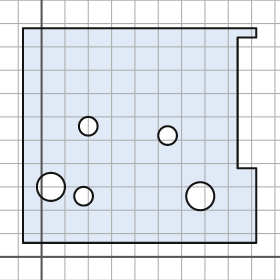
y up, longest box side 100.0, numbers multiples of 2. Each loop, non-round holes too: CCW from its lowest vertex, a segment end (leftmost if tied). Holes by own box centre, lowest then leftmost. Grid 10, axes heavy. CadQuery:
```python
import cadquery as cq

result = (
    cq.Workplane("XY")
    .moveTo(-8.0, 6.0)
    .lineTo(92.0, 6.0)
    .lineTo(92.0, 38.0)
    .lineTo(84.0, 38.0)
    .lineTo(84.0, 94.0)
    .lineTo(92.0, 94.0)
    .lineTo(92.0, 98.0)
    .lineTo(-8.0, 98.0)
    .close()
    .moveTo(18.0, 26.0)
    .circle(4.0)
    .moveTo(68.0, 26.0)
    .circle(6.0)
    .moveTo(4.0, 30.0)
    .circle(6.0)
    .moveTo(54.0, 52.0)
    .circle(4.0)
    .moveTo(20.0, 56.0)
    .circle(4.0)
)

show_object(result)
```